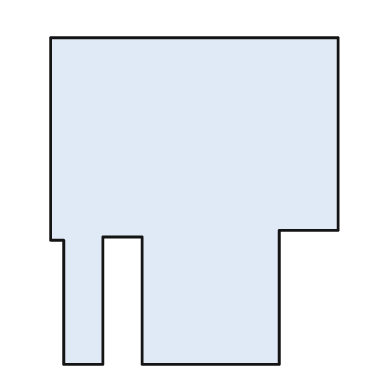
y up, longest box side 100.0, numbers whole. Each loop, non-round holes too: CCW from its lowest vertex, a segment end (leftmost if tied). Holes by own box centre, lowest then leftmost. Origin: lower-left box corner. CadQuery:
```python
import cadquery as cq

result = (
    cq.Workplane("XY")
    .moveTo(4.0, 0.0)
    .lineTo(16.0, 0.0)
    .lineTo(16.0, 39.0)
    .lineTo(28.0, 39.0)
    .lineTo(28.0, 0.0)
    .lineTo(70.0, 0.0)
    .lineTo(70.0, 41.0)
    .lineTo(88.0, 41.0)
    .lineTo(88.0, 100.0)
    .lineTo(0.0, 100.0)
    .lineTo(0.0, 38.0)
    .lineTo(4.0, 38.0)
    .close()
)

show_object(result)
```